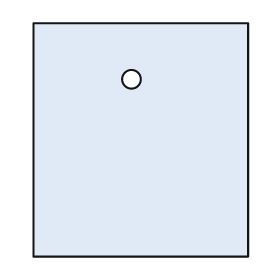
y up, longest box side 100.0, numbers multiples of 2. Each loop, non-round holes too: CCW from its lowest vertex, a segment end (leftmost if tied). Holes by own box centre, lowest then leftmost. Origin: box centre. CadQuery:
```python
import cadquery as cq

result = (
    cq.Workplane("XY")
    .moveTo(-46.0, -50.0)
    .lineTo(46.0, -50.0)
    .lineTo(46.0, 50.0)
    .lineTo(-46.0, 50.0)
    .close()
    .moveTo(-4.0, 26.0)
    .circle(4.0)
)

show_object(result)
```